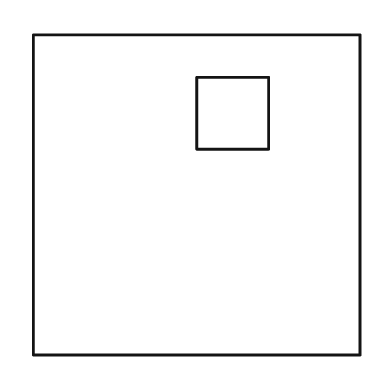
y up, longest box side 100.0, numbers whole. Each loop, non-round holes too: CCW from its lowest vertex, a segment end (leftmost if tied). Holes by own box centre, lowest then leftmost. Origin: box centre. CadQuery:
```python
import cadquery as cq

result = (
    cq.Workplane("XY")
    .moveTo(-50.0, -49.0)
    .lineTo(50.0, -49.0)
    .lineTo(50.0, 49.0)
    .lineTo(-50.0, 49.0)
    .close()
    .moveTo(0.0, 14.0)
    .lineTo(22.0, 14.0)
    .lineTo(22.0, 36.0)
    .lineTo(0.0, 36.0)
    .close()
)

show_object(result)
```